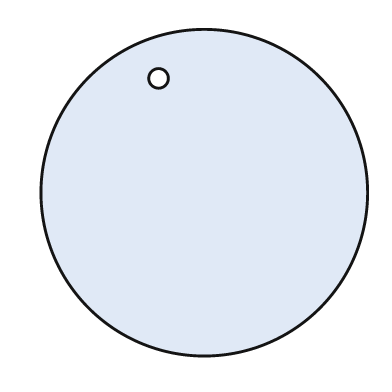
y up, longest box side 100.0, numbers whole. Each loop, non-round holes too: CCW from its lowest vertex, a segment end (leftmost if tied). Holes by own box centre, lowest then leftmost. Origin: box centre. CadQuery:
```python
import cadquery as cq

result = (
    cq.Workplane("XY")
    .moveTo(0.0, 0.0)
    .circle(50.0)
    .moveTo(-14.0, 35.0)
    .circle(3.0)
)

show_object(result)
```